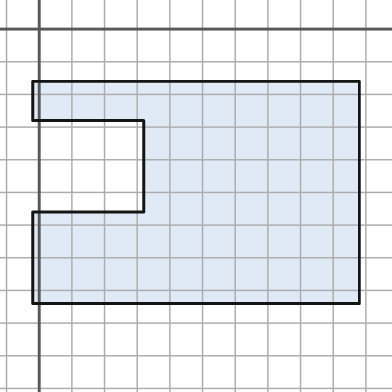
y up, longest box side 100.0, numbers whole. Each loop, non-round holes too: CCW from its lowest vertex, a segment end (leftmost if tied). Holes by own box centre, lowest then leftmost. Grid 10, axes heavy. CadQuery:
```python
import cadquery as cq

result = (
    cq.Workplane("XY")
    .moveTo(-2.0, -84.0)
    .lineTo(98.0, -84.0)
    .lineTo(98.0, -16.0)
    .lineTo(-2.0, -16.0)
    .lineTo(-2.0, -28.0)
    .lineTo(32.0, -28.0)
    .lineTo(32.0, -56.0)
    .lineTo(-2.0, -56.0)
    .close()
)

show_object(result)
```